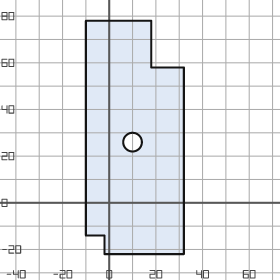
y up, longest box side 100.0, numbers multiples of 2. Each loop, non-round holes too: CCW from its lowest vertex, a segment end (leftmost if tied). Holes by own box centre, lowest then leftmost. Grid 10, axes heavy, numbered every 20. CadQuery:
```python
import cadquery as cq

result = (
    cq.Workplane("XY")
    .moveTo(-2.0, -22.0)
    .lineTo(32.0, -22.0)
    .lineTo(32.0, 58.0)
    .lineTo(18.0, 58.0)
    .lineTo(18.0, 78.0)
    .lineTo(-10.0, 78.0)
    .lineTo(-10.0, -14.0)
    .lineTo(-2.0, -14.0)
    .close()
    .moveTo(10.0, 26.0)
    .circle(4.0)
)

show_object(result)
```